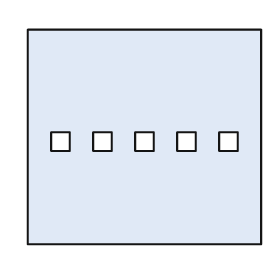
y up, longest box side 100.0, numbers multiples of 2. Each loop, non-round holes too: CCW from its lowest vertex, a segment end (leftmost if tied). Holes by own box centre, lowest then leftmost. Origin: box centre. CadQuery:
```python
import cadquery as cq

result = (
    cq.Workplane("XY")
    .moveTo(-50.0, -46.0)
    .lineTo(50.0, -46.0)
    .lineTo(50.0, 46.0)
    .lineTo(-50.0, 46.0)
    .close()
    .moveTo(-40.0, -6.0)
    .lineTo(-32.0, -6.0)
    .lineTo(-32.0, 2.0)
    .lineTo(-40.0, 2.0)
    .close()
    .moveTo(-22.0, -6.0)
    .lineTo(-14.0, -6.0)
    .lineTo(-14.0, 2.0)
    .lineTo(-22.0, 2.0)
    .close()
    .moveTo(-4.0, -6.0)
    .lineTo(4.0, -6.0)
    .lineTo(4.0, 2.0)
    .lineTo(-4.0, 2.0)
    .close()
    .moveTo(14.0, -6.0)
    .lineTo(22.0, -6.0)
    .lineTo(22.0, 2.0)
    .lineTo(14.0, 2.0)
    .close()
    .moveTo(32.0, -6.0)
    .lineTo(40.0, -6.0)
    .lineTo(40.0, 2.0)
    .lineTo(32.0, 2.0)
    .close()
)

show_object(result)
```